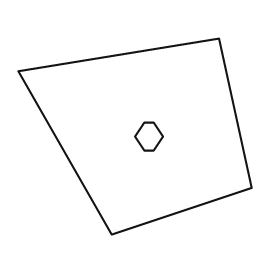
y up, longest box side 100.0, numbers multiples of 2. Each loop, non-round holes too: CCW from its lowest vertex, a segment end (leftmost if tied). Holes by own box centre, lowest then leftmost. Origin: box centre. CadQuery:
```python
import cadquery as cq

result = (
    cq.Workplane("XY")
    .moveTo(-10.0, -42.0)
    .lineTo(50.0, -22.0)
    .lineTo(36.0, 42.0)
    .lineTo(-50.0, 28.0)
    .close()
    .moveTo(4.0, -6.0)
    .lineTo(8.0, -6.0)
    .lineTo(12.0, 0.0)
    .lineTo(8.0, 6.0)
    .lineTo(4.0, 6.0)
    .lineTo(0.0, 0.0)
    .close()
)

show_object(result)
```